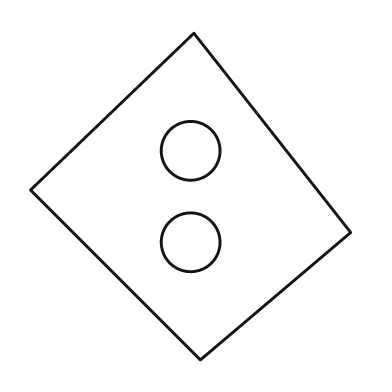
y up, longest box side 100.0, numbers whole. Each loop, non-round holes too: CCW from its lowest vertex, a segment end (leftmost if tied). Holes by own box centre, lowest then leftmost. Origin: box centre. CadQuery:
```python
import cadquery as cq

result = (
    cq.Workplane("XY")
    .moveTo(3.0, -50.0)
    .lineTo(49.0, -11.0)
    .lineTo(1.0, 50.0)
    .lineTo(-49.0, 2.0)
    .close()
    .moveTo(0.0, -14.0)
    .circle(9.0)
    .moveTo(0.0, 14.0)
    .circle(9.0)
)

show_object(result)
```